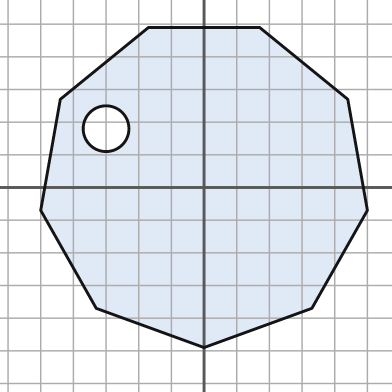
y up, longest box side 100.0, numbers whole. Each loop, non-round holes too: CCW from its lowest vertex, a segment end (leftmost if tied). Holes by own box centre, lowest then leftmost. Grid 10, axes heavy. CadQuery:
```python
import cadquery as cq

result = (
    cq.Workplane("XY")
    .moveTo(0.0, -49.0)
    .lineTo(33.0, -37.0)
    .lineTo(50.0, -7.0)
    .lineTo(44.0, 27.0)
    .lineTo(17.0, 49.0)
    .lineTo(-17.0, 49.0)
    .lineTo(-44.0, 27.0)
    .lineTo(-50.0, -7.0)
    .lineTo(-33.0, -37.0)
    .close()
    .moveTo(-30.0, 18.0)
    .circle(7.0)
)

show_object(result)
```